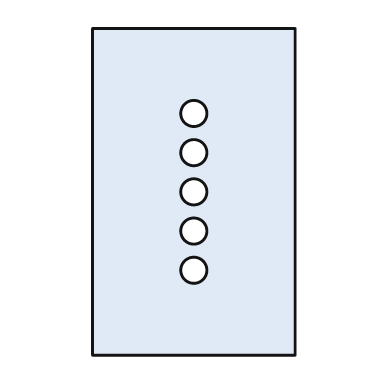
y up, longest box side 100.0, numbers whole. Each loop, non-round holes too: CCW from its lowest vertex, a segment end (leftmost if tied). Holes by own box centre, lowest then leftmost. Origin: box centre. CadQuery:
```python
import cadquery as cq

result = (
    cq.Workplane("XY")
    .moveTo(-31.0, -50.0)
    .lineTo(31.0, -50.0)
    .lineTo(31.0, 50.0)
    .lineTo(-31.0, 50.0)
    .close()
    .moveTo(0.0, -24.0)
    .circle(4.0)
    .moveTo(0.0, -12.0)
    .circle(4.0)
    .moveTo(0.0, 0.0)
    .circle(4.0)
    .moveTo(0.0, 12.0)
    .circle(4.0)
    .moveTo(0.0, 24.0)
    .circle(4.0)
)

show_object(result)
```